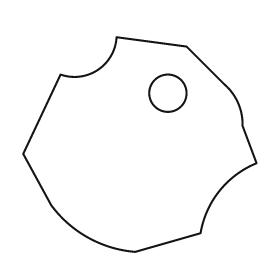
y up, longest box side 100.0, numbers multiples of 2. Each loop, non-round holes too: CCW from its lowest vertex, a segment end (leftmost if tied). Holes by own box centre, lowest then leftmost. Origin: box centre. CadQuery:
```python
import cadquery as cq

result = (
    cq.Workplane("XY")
    .moveTo(-2.0, -46.0)
    .lineTo(26.0, -38.0)
    .threePointArc((34.0, -20.0), (50.0, -8.0))
    .lineTo(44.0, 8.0)
    .threePointArc((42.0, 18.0), (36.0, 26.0))
    .lineTo(20.0, 42.0)
    .lineTo(-10.0, 46.0)
    .threePointArc((-18.0, 32.0), (-34.0, 30.0))
    .lineTo(-50.0, -4.0)
    .lineTo(-38.0, -26.0)
    .threePointArc((-22.0, -40.0), (-2.0, -46.0))
    .close()
    .moveTo(12.0, 22.0)
    .circle(8.0)
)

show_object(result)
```